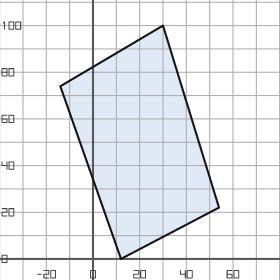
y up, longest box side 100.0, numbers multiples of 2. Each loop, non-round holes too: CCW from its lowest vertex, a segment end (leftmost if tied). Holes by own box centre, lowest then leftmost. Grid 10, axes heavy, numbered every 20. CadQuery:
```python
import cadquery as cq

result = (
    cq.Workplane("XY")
    .moveTo(12.0, 0.0)
    .lineTo(54.0, 22.0)
    .lineTo(30.0, 100.0)
    .lineTo(-14.0, 74.0)
    .close()
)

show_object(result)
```